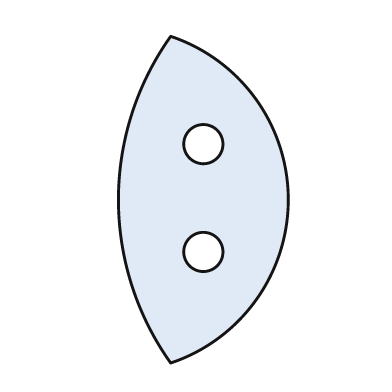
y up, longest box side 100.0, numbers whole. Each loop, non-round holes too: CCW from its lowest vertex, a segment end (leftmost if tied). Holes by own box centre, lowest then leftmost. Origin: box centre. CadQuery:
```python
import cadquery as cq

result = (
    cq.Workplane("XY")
    .moveTo(-10.0, -50.0)
    .threePointArc((26.0, 0.0), (-10.0, 50.0))
    .threePointArc((-26.0, 0.0), (-10.0, -50.0))
    .close()
    .moveTo(0.0, -16.0)
    .circle(6.0)
    .moveTo(0.0, 17.0)
    .circle(6.0)
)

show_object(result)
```